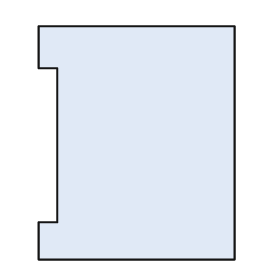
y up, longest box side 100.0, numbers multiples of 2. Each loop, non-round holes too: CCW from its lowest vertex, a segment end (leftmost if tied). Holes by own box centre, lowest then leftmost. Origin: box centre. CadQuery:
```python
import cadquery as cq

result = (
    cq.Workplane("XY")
    .moveTo(-42.0, -50.0)
    .lineTo(42.0, -50.0)
    .lineTo(42.0, 50.0)
    .lineTo(-42.0, 50.0)
    .lineTo(-42.0, 32.0)
    .lineTo(-34.0, 32.0)
    .lineTo(-34.0, -34.0)
    .lineTo(-42.0, -34.0)
    .close()
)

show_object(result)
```